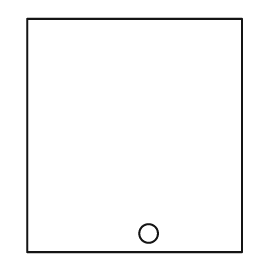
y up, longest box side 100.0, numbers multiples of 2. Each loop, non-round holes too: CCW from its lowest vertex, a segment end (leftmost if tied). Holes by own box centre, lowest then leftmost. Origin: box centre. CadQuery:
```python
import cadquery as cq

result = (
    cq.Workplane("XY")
    .moveTo(-46.0, -50.0)
    .lineTo(46.0, -50.0)
    .lineTo(46.0, 50.0)
    .lineTo(-46.0, 50.0)
    .close()
    .moveTo(6.0, -42.0)
    .circle(4.0)
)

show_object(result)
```